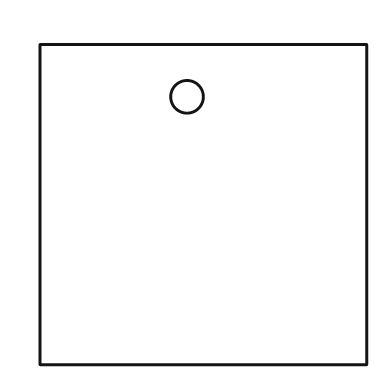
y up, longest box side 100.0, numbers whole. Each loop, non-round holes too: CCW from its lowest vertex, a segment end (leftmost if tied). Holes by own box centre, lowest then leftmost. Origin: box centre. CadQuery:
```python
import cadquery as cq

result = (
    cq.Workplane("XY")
    .moveTo(-50.0, -49.0)
    .lineTo(50.0, -49.0)
    .lineTo(50.0, 49.0)
    .lineTo(-50.0, 49.0)
    .close()
    .moveTo(-5.0, 33.0)
    .circle(5.0)
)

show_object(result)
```